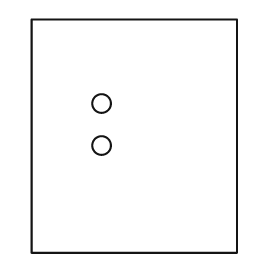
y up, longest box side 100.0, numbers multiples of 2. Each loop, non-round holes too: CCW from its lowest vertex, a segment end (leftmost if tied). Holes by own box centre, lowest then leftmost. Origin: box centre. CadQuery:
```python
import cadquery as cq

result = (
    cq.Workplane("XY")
    .moveTo(-44.0, -50.0)
    .lineTo(44.0, -50.0)
    .lineTo(44.0, 50.0)
    .lineTo(-44.0, 50.0)
    .close()
    .moveTo(-14.0, -4.0)
    .circle(4.0)
    .moveTo(-14.0, 14.0)
    .circle(4.0)
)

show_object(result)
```